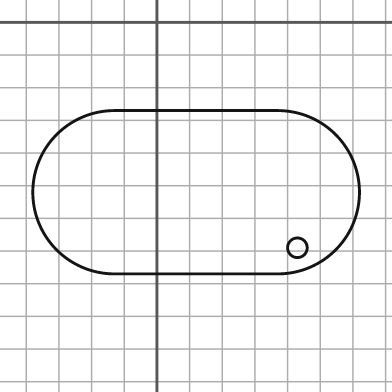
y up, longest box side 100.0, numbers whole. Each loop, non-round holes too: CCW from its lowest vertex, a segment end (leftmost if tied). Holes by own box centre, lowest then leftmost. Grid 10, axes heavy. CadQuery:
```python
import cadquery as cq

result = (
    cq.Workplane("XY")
    .moveTo(-13.0, -77.0)
    .lineTo(37.0, -77.0)
    .threePointArc((62.0, -52.0), (37.0, -27.0))
    .lineTo(-13.0, -27.0)
    .threePointArc((-38.0, -52.0), (-13.0, -77.0))
    .close()
    .moveTo(43.0, -69.0)
    .circle(3.0)
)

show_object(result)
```